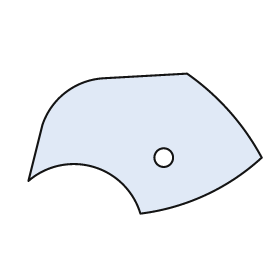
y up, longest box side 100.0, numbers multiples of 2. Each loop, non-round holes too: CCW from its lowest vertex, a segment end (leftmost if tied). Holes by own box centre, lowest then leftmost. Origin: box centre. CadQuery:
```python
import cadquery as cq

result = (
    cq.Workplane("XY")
    .moveTo(-2.0, -30.0)
    .threePointArc((26.0, -22.0), (50.0, -6.0))
    .threePointArc((36.0, 14.0), (18.0, 30.0))
    .lineTo(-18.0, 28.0)
    .threePointArc((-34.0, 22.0), (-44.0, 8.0))
    .lineTo(-50.0, -16.0)
    .threePointArc((-22.0, -10.0), (-2.0, -30.0))
    .close()
    .moveTo(8.0, -6.0)
    .circle(4.0)
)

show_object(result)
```